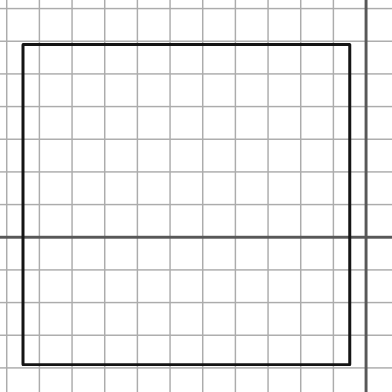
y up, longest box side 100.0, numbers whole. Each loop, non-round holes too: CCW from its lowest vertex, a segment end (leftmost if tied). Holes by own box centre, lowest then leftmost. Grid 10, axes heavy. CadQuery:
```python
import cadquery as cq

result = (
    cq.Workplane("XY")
    .moveTo(-105.0, -39.0)
    .lineTo(-5.0, -39.0)
    .lineTo(-5.0, 59.0)
    .lineTo(-105.0, 59.0)
    .close()
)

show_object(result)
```